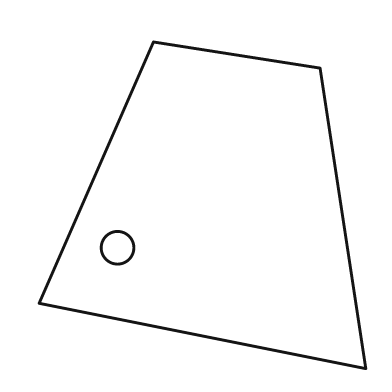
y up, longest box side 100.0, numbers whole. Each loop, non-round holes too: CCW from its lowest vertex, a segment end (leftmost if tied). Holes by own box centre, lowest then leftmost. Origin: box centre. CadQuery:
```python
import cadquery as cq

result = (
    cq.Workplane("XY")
    .moveTo(50.0, -50.0)
    .lineTo(36.0, 42.0)
    .lineTo(-15.0, 50.0)
    .lineTo(-50.0, -30.0)
    .close()
    .moveTo(-26.0, -13.0)
    .circle(5.0)
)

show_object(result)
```